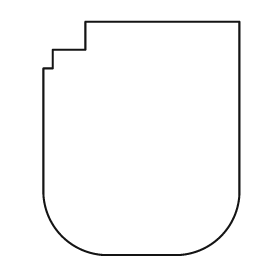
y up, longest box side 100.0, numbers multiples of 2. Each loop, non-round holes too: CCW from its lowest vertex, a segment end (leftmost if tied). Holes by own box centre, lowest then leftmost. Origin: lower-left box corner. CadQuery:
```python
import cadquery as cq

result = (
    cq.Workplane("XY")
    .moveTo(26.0, 0.0)
    .lineTo(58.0, 0.0)
    .threePointArc((76.0, 8.0), (84.0, 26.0))
    .lineTo(84.0, 100.0)
    .lineTo(18.0, 100.0)
    .lineTo(18.0, 88.0)
    .lineTo(4.0, 88.0)
    .lineTo(4.0, 80.0)
    .lineTo(0.0, 80.0)
    .lineTo(0.0, 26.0)
    .threePointArc((8.0, 8.0), (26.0, 0.0))
    .close()
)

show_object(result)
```